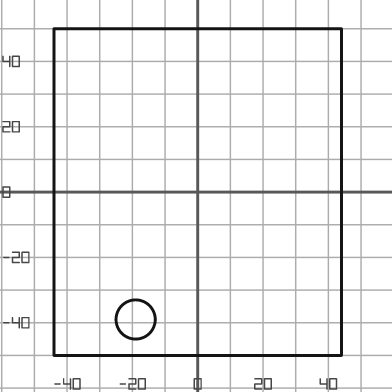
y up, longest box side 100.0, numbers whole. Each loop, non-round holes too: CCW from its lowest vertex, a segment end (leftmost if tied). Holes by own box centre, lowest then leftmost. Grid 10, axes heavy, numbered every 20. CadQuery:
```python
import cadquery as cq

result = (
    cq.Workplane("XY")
    .moveTo(-44.0, -50.0)
    .lineTo(44.0, -50.0)
    .lineTo(44.0, 50.0)
    .lineTo(-44.0, 50.0)
    .close()
    .moveTo(-19.0, -39.0)
    .circle(6.0)
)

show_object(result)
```